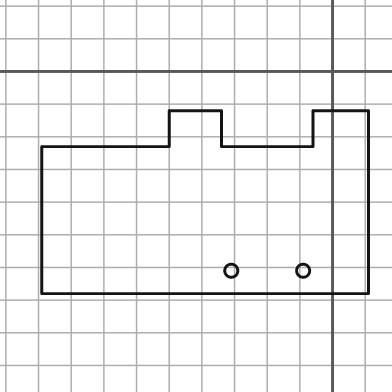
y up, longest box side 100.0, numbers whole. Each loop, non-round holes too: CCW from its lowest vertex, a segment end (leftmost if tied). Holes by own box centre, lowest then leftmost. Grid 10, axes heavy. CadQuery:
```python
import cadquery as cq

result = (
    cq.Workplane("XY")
    .moveTo(-89.0, -68.0)
    .lineTo(11.0, -68.0)
    .lineTo(11.0, -12.0)
    .lineTo(-6.0, -12.0)
    .lineTo(-6.0, -23.0)
    .lineTo(-34.0, -23.0)
    .lineTo(-34.0, -12.0)
    .lineTo(-50.0, -12.0)
    .lineTo(-50.0, -23.0)
    .lineTo(-89.0, -23.0)
    .close()
    .moveTo(-31.0, -61.0)
    .circle(2.0)
    .moveTo(-9.0, -61.0)
    .circle(2.0)
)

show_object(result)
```